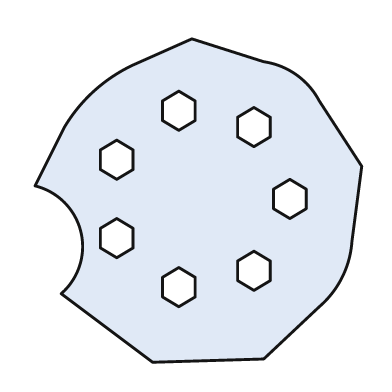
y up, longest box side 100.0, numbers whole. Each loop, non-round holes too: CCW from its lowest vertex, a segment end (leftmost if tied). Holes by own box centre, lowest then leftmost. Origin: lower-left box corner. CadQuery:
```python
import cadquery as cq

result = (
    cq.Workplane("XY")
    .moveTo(36.0, 0.0)
    .lineTo(70.0, 1.0)
    .lineTo(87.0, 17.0)
    .threePointArc((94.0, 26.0), (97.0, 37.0))
    .lineTo(100.0, 60.0)
    .lineTo(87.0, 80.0)
    .threePointArc((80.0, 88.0), (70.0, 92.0))
    .lineTo(48.0, 99.0)
    .lineTo(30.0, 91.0)
    .threePointArc((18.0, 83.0), (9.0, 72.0))
    .lineTo(0.0, 54.0)
    .threePointArc((14.0, 40.0), (8.0, 21.0))
    .close()
    .moveTo(44.0, 17.0)
    .lineTo(49.0, 20.0)
    .lineTo(49.0, 26.0)
    .lineTo(44.0, 29.0)
    .lineTo(39.0, 26.0)
    .lineTo(39.0, 20.0)
    .close()
    .moveTo(67.0, 22.0)
    .lineTo(72.0, 25.0)
    .lineTo(72.0, 31.0)
    .lineTo(67.0, 34.0)
    .lineTo(62.0, 31.0)
    .lineTo(62.0, 25.0)
    .close()
    .moveTo(25.0, 32.0)
    .lineTo(30.0, 35.0)
    .lineTo(30.0, 41.0)
    .lineTo(25.0, 44.0)
    .lineTo(20.0, 41.0)
    .lineTo(20.0, 35.0)
    .close()
    .moveTo(78.0, 44.0)
    .lineTo(83.0, 47.0)
    .lineTo(83.0, 53.0)
    .lineTo(78.0, 56.0)
    .lineTo(73.0, 53.0)
    .lineTo(73.0, 47.0)
    .close()
    .moveTo(25.0, 56.0)
    .lineTo(30.0, 59.0)
    .lineTo(30.0, 65.0)
    .lineTo(25.0, 68.0)
    .lineTo(20.0, 65.0)
    .lineTo(20.0, 59.0)
    .close()
    .moveTo(67.0, 66.0)
    .lineTo(72.0, 69.0)
    .lineTo(72.0, 75.0)
    .lineTo(67.0, 78.0)
    .lineTo(62.0, 75.0)
    .lineTo(62.0, 69.0)
    .close()
    .moveTo(44.0, 71.0)
    .lineTo(49.0, 74.0)
    .lineTo(49.0, 80.0)
    .lineTo(44.0, 83.0)
    .lineTo(39.0, 80.0)
    .lineTo(39.0, 74.0)
    .close()
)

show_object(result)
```